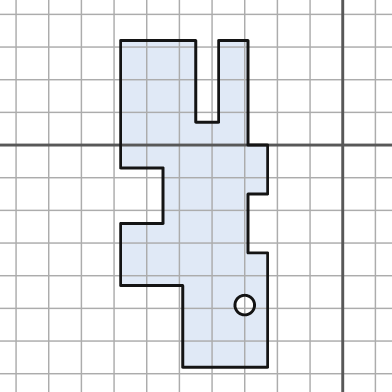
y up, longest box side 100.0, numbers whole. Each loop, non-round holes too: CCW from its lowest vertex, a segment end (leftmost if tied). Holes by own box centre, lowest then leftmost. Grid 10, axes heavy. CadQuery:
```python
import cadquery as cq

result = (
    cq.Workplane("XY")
    .moveTo(-49.0, -68.0)
    .lineTo(-23.0, -68.0)
    .lineTo(-23.0, -33.0)
    .lineTo(-29.0, -33.0)
    .lineTo(-29.0, -15.0)
    .lineTo(-23.0, -15.0)
    .lineTo(-23.0, 0.0)
    .lineTo(-29.0, 0.0)
    .lineTo(-29.0, 32.0)
    .lineTo(-38.0, 32.0)
    .lineTo(-38.0, 7.0)
    .lineTo(-45.0, 7.0)
    .lineTo(-45.0, 32.0)
    .lineTo(-68.0, 32.0)
    .lineTo(-68.0, -7.0)
    .lineTo(-55.0, -7.0)
    .lineTo(-55.0, -24.0)
    .lineTo(-68.0, -24.0)
    .lineTo(-68.0, -43.0)
    .lineTo(-49.0, -43.0)
    .close()
    .moveTo(-30.0, -49.0)
    .circle(3.0)
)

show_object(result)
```